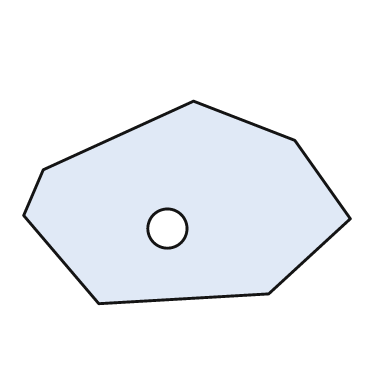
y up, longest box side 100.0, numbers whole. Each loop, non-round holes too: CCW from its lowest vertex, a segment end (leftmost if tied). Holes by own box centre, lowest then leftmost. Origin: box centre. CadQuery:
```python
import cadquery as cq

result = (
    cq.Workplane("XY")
    .moveTo(-27.0, -31.0)
    .lineTo(25.0, -28.0)
    .lineTo(50.0, -5.0)
    .lineTo(33.0, 19.0)
    .lineTo(2.0, 31.0)
    .lineTo(-44.0, 10.0)
    .lineTo(-50.0, -4.0)
    .close()
    .moveTo(-6.0, -8.0)
    .circle(6.0)
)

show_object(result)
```